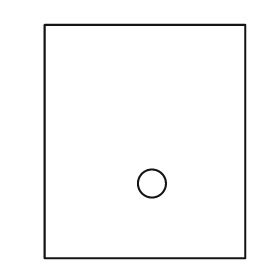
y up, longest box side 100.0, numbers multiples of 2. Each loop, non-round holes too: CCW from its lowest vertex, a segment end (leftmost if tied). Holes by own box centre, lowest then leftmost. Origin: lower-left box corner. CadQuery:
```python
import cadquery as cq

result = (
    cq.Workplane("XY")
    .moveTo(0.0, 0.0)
    .lineTo(86.0, 0.0)
    .lineTo(86.0, 100.0)
    .lineTo(0.0, 100.0)
    .close()
    .moveTo(46.0, 32.0)
    .circle(6.0)
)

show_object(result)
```